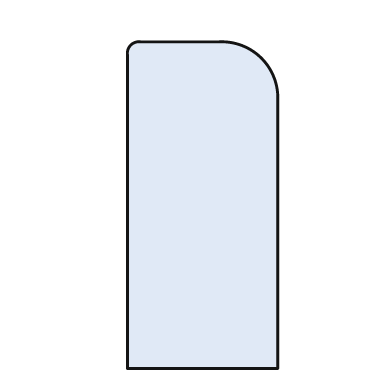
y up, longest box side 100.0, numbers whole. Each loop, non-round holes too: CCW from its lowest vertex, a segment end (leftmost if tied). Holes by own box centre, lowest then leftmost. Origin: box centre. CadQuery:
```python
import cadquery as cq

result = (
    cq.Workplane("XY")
    .moveTo(-23.0, -50.0)
    .lineTo(23.0, -50.0)
    .lineTo(23.0, 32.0)
    .threePointArc((18.0, 45.0), (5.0, 50.0))
    .lineTo(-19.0, 50.0)
    .threePointArc((-22.0, 49.0), (-23.0, 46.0))
    .close()
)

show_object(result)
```